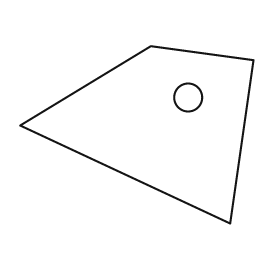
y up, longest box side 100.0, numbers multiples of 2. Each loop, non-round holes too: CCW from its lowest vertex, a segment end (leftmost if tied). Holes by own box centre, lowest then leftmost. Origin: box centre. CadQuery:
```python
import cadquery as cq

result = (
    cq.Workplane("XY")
    .moveTo(40.0, -38.0)
    .lineTo(50.0, 32.0)
    .lineTo(6.0, 38.0)
    .lineTo(-50.0, 4.0)
    .close()
    .moveTo(22.0, 16.0)
    .circle(6.0)
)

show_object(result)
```